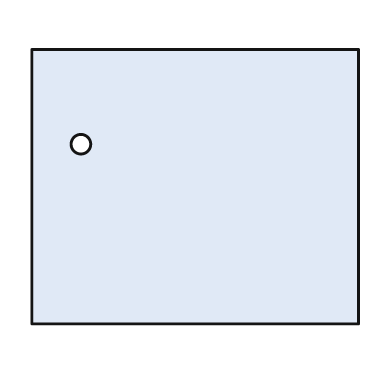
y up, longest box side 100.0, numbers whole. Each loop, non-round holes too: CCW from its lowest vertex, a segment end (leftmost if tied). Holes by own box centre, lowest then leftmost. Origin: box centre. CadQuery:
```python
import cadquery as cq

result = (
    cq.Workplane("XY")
    .moveTo(-50.0, -42.0)
    .lineTo(50.0, -42.0)
    .lineTo(50.0, 42.0)
    .lineTo(-50.0, 42.0)
    .close()
    .moveTo(-35.0, 13.0)
    .circle(3.0)
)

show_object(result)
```